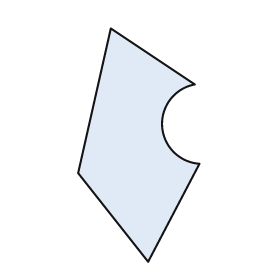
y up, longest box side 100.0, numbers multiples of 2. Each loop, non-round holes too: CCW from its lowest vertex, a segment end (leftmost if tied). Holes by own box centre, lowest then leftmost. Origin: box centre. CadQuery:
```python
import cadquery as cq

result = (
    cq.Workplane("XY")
    .moveTo(4.0, -50.0)
    .lineTo(26.0, -8.0)
    .threePointArc((10.0, 8.0), (24.0, 26.0))
    .lineTo(-12.0, 50.0)
    .lineTo(-26.0, -12.0)
    .close()
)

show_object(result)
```